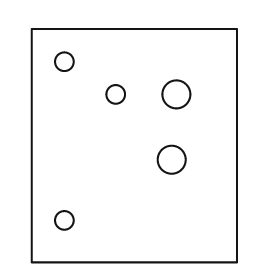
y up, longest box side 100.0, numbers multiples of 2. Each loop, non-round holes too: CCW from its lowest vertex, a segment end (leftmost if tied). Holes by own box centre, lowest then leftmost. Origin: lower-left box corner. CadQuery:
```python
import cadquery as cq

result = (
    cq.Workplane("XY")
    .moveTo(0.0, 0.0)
    .lineTo(88.0, 0.0)
    .lineTo(88.0, 100.0)
    .lineTo(0.0, 100.0)
    .close()
    .moveTo(14.0, 18.0)
    .circle(4.0)
    .moveTo(60.0, 44.0)
    .circle(6.0)
    .moveTo(36.0, 72.0)
    .circle(4.0)
    .moveTo(62.0, 72.0)
    .circle(6.0)
    .moveTo(14.0, 86.0)
    .circle(4.0)
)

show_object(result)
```